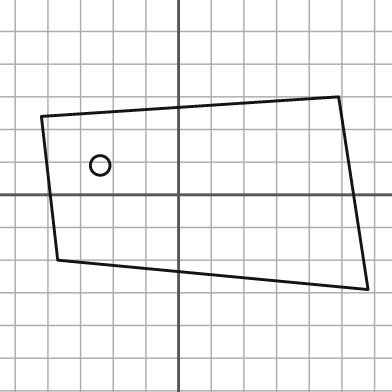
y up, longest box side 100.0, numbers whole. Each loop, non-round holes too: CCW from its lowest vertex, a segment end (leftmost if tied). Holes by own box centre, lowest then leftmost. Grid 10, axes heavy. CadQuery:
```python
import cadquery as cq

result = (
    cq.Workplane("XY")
    .moveTo(58.0, -29.0)
    .lineTo(49.0, 30.0)
    .lineTo(-42.0, 24.0)
    .lineTo(-37.0, -20.0)
    .close()
    .moveTo(-24.0, 9.0)
    .circle(3.0)
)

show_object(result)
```